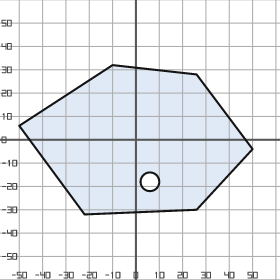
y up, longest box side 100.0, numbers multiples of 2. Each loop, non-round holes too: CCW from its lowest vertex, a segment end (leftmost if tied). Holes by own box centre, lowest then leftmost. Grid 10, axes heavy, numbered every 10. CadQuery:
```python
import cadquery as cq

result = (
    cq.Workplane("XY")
    .moveTo(-22.0, -32.0)
    .lineTo(26.0, -30.0)
    .lineTo(50.0, -4.0)
    .lineTo(26.0, 28.0)
    .lineTo(-10.0, 32.0)
    .lineTo(-50.0, 6.0)
    .close()
    .moveTo(6.0, -18.0)
    .circle(4.0)
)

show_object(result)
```